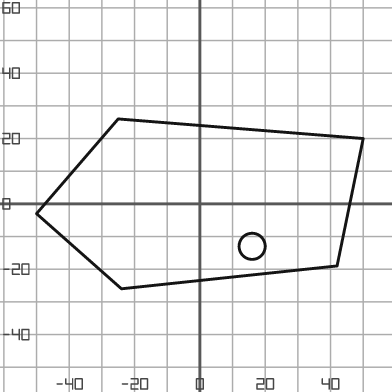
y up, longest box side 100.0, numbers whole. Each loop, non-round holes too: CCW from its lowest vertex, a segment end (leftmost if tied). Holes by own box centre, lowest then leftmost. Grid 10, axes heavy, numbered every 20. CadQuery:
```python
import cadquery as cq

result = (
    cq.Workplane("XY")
    .moveTo(-24.0, -26.0)
    .lineTo(42.0, -19.0)
    .lineTo(50.0, 20.0)
    .lineTo(-25.0, 26.0)
    .lineTo(-50.0, -3.0)
    .close()
    .moveTo(16.0, -13.0)
    .circle(4.0)
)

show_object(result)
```